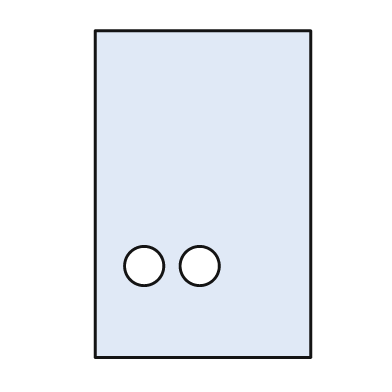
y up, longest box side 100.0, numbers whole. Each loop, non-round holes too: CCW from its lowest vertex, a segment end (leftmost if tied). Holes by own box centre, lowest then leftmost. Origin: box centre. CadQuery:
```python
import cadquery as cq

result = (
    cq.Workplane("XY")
    .moveTo(-33.0, -50.0)
    .lineTo(33.0, -50.0)
    .lineTo(33.0, 50.0)
    .lineTo(-33.0, 50.0)
    .close()
    .moveTo(-18.0, -22.0)
    .circle(6.0)
    .moveTo(-1.0, -22.0)
    .circle(6.0)
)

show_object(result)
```